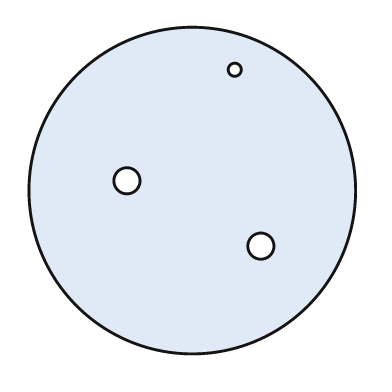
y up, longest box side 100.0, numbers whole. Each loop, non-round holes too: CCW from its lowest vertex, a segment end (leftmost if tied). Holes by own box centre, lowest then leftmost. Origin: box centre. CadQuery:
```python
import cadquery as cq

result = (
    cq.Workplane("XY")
    .moveTo(0.0, 0.0)
    .circle(50.0)
    .moveTo(21.0, -17.0)
    .circle(4.0)
    .moveTo(-20.0, 3.0)
    .circle(4.0)
    .moveTo(13.0, 37.0)
    .circle(2.0)
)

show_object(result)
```